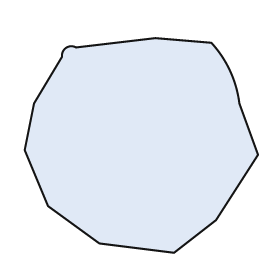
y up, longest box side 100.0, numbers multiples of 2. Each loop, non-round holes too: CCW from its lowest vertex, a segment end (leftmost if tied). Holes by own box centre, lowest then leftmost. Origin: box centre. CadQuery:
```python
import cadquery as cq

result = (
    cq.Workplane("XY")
    .moveTo(14.0, -46.0)
    .lineTo(32.0, -32.0)
    .lineTo(50.0, -4.0)
    .lineTo(42.0, 18.0)
    .threePointArc((38.0, 32.0), (30.0, 44.0))
    .lineTo(6.0, 46.0)
    .lineTo(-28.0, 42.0)
    .threePointArc((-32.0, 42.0), (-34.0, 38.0))
    .lineTo(-46.0, 18.0)
    .lineTo(-50.0, -2.0)
    .lineTo(-40.0, -26.0)
    .lineTo(-18.0, -42.0)
    .close()
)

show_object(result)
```